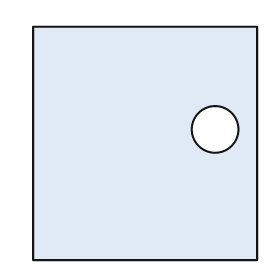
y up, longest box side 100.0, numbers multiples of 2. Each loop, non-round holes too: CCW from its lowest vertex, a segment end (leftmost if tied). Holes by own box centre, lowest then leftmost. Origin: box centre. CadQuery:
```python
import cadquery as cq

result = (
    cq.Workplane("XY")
    .moveTo(-48.0, -50.0)
    .lineTo(48.0, -50.0)
    .lineTo(48.0, 50.0)
    .lineTo(-48.0, 50.0)
    .close()
    .moveTo(30.0, 6.0)
    .circle(10.0)
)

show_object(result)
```